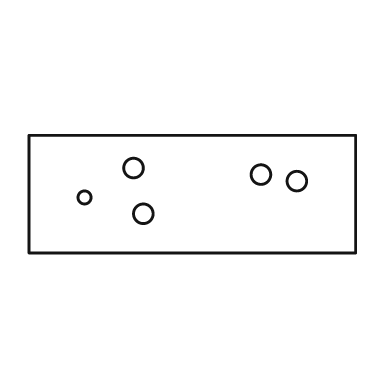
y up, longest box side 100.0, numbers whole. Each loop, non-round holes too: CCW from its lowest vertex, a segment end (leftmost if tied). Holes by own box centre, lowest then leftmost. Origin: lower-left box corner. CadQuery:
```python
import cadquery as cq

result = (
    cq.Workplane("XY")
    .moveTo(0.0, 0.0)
    .lineTo(100.0, 0.0)
    .lineTo(100.0, 36.0)
    .lineTo(0.0, 36.0)
    .close()
    .moveTo(35.0, 12.0)
    .circle(3.0)
    .moveTo(17.0, 17.0)
    .circle(2.0)
    .moveTo(82.0, 22.0)
    .circle(3.0)
    .moveTo(71.0, 24.0)
    .circle(3.0)
    .moveTo(32.0, 26.0)
    .circle(3.0)
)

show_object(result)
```